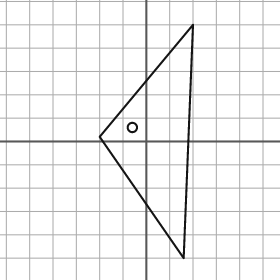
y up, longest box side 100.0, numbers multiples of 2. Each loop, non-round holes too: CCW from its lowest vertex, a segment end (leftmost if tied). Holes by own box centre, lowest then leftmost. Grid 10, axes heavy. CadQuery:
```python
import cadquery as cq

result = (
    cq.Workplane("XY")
    .moveTo(16.0, -50.0)
    .lineTo(20.0, 50.0)
    .lineTo(-20.0, 2.0)
    .close()
    .moveTo(-6.0, 6.0)
    .circle(2.0)
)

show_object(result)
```